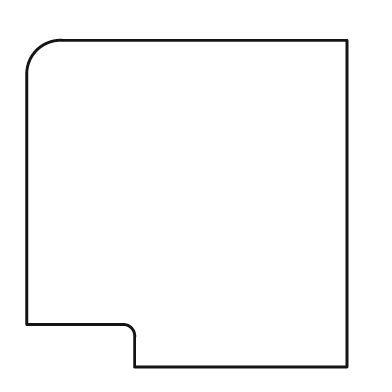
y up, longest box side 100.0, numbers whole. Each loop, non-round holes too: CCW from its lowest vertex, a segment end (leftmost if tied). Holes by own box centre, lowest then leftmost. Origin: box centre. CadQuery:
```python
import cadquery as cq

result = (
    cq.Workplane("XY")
    .moveTo(-16.0, -50.0)
    .lineTo(49.0, -50.0)
    .lineTo(49.0, 50.0)
    .lineTo(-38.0, 50.0)
    .threePointArc((-46.0, 47.0), (-49.0, 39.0))
    .lineTo(-49.0, -37.0)
    .lineTo(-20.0, -37.0)
    .threePointArc((-17.0, -38.0), (-16.0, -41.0))
    .close()
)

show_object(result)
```